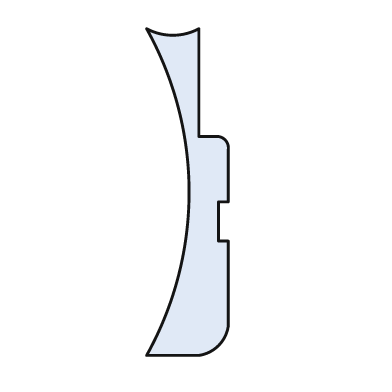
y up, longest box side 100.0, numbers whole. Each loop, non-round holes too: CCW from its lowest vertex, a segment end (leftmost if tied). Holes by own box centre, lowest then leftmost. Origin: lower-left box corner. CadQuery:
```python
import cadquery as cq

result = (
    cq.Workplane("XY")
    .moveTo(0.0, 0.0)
    .lineTo(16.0, 0.0)
    .threePointArc((22.0, 3.0), (25.0, 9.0))
    .lineTo(25.0, 35.0)
    .lineTo(22.0, 35.0)
    .lineTo(22.0, 47.0)
    .lineTo(25.0, 47.0)
    .lineTo(25.0, 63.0)
    .threePointArc((24.0, 66.0), (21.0, 67.0))
    .lineTo(16.0, 67.0)
    .lineTo(16.0, 100.0)
    .threePointArc((8.0, 98.0), (0.0, 100.0))
    .threePointArc((13.0, 50.0), (0.0, 0.0))
    .close()
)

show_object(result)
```